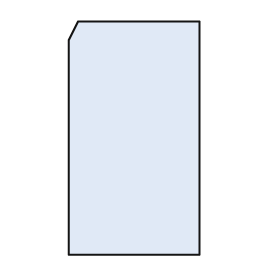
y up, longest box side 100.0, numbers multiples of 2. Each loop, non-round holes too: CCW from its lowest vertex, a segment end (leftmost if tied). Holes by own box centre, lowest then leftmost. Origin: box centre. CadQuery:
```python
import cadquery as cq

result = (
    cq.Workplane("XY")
    .moveTo(-28.0, -50.0)
    .lineTo(28.0, -50.0)
    .lineTo(28.0, 50.0)
    .lineTo(-24.0, 50.0)
    .lineTo(-28.0, 42.0)
    .close()
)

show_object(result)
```